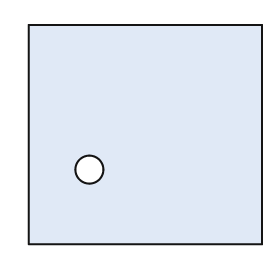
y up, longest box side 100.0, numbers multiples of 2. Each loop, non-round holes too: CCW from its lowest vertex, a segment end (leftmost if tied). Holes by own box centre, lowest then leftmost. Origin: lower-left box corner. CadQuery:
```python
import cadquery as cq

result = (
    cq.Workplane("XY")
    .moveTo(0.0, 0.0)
    .lineTo(100.0, 0.0)
    .lineTo(100.0, 94.0)
    .lineTo(0.0, 94.0)
    .close()
    .moveTo(26.0, 32.0)
    .circle(6.0)
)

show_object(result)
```